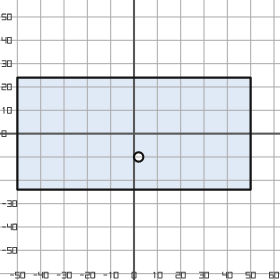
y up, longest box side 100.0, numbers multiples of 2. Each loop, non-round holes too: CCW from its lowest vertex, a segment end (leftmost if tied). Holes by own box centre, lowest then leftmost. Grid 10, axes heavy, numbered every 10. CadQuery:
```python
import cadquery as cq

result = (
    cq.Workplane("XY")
    .moveTo(-50.0, -24.0)
    .lineTo(50.0, -24.0)
    .lineTo(50.0, 24.0)
    .lineTo(-50.0, 24.0)
    .close()
    .moveTo(2.0, -10.0)
    .circle(2.0)
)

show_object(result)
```